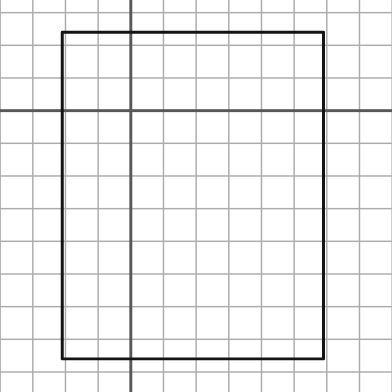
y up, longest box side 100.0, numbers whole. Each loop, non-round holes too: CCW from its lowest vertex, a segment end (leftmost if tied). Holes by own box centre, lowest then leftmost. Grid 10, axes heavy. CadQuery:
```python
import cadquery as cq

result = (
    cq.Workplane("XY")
    .moveTo(-21.0, -76.0)
    .lineTo(59.0, -76.0)
    .lineTo(59.0, 24.0)
    .lineTo(-21.0, 24.0)
    .close()
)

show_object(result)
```